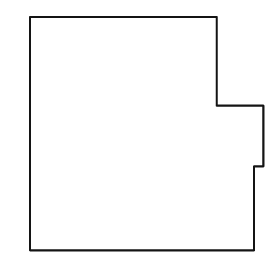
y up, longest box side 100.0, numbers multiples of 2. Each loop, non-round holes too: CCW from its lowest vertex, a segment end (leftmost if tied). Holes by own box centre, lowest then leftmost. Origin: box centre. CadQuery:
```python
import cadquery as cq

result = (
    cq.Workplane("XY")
    .moveTo(-50.0, -50.0)
    .lineTo(46.0, -50.0)
    .lineTo(46.0, -14.0)
    .lineTo(50.0, -14.0)
    .lineTo(50.0, 12.0)
    .lineTo(30.0, 12.0)
    .lineTo(30.0, 50.0)
    .lineTo(-50.0, 50.0)
    .close()
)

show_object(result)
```